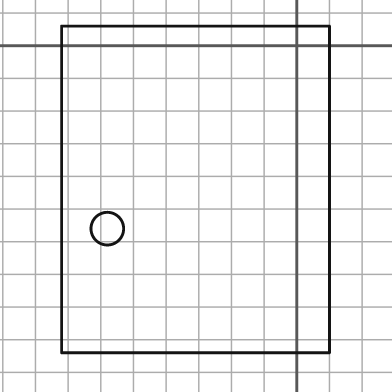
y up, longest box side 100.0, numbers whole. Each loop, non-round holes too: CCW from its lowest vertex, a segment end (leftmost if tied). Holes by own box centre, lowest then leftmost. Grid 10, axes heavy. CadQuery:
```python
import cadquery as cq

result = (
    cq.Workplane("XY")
    .moveTo(-72.0, -94.0)
    .lineTo(10.0, -94.0)
    .lineTo(10.0, 6.0)
    .lineTo(-72.0, 6.0)
    .close()
    .moveTo(-58.0, -56.0)
    .circle(5.0)
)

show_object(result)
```